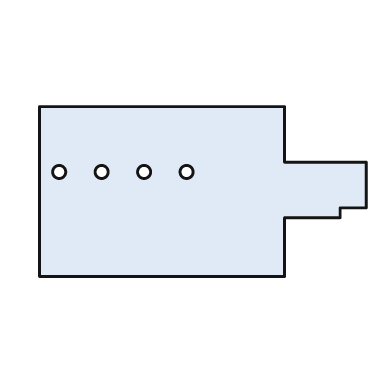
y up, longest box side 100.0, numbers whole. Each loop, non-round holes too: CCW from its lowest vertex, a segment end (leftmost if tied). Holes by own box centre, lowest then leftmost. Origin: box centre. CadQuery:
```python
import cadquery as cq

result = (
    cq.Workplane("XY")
    .moveTo(-50.0, -26.0)
    .lineTo(25.0, -26.0)
    .lineTo(25.0, -8.0)
    .lineTo(42.0, -8.0)
    .lineTo(42.0, -5.0)
    .lineTo(50.0, -5.0)
    .lineTo(50.0, 9.0)
    .lineTo(25.0, 9.0)
    .lineTo(25.0, 26.0)
    .lineTo(-50.0, 26.0)
    .close()
    .moveTo(-44.0, 6.0)
    .circle(2.0)
    .moveTo(-31.0, 6.0)
    .circle(2.0)
    .moveTo(-18.0, 6.0)
    .circle(2.0)
    .moveTo(-5.0, 6.0)
    .circle(2.0)
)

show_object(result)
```